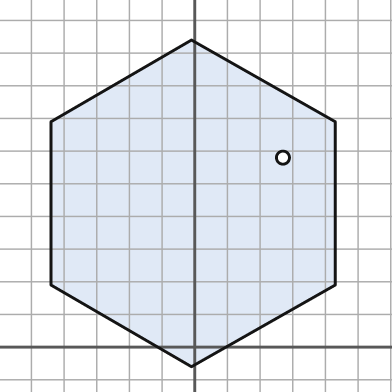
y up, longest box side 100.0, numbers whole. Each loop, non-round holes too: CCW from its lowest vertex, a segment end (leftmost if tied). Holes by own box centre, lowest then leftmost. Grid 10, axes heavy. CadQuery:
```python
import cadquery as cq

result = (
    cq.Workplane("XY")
    .moveTo(-1.0, -6.0)
    .lineTo(43.0, 19.0)
    .lineTo(43.0, 69.0)
    .lineTo(-1.0, 94.0)
    .lineTo(-44.0, 69.0)
    .lineTo(-44.0, 19.0)
    .close()
    .moveTo(27.0, 58.0)
    .circle(2.0)
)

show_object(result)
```